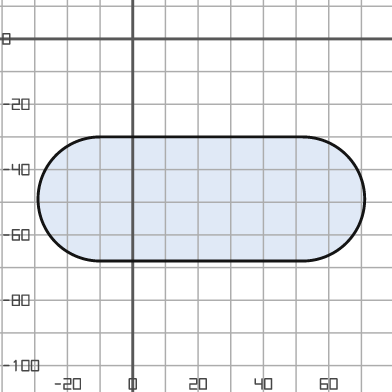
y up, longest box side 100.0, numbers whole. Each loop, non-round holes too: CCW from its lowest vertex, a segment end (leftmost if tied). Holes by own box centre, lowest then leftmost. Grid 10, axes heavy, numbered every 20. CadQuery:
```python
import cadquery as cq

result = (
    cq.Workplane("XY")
    .moveTo(-10.0, -68.0)
    .lineTo(52.0, -68.0)
    .threePointArc((71.0, -49.0), (52.0, -30.0))
    .lineTo(-10.0, -30.0)
    .threePointArc((-29.0, -49.0), (-10.0, -68.0))
    .close()
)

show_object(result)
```